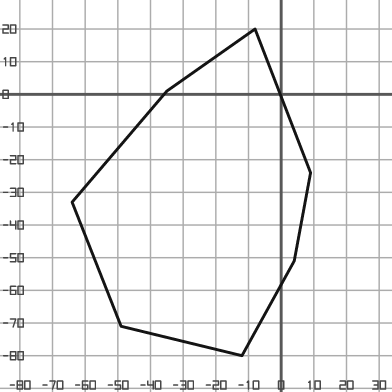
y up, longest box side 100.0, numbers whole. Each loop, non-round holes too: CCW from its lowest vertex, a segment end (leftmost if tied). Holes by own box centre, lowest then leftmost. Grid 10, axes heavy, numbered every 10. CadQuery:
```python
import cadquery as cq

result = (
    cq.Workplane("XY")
    .moveTo(-12.0, -80.0)
    .lineTo(4.0, -51.0)
    .lineTo(9.0, -24.0)
    .lineTo(-8.0, 20.0)
    .lineTo(-35.0, 1.0)
    .lineTo(-64.0, -33.0)
    .lineTo(-49.0, -71.0)
    .close()
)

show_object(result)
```